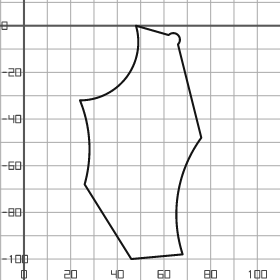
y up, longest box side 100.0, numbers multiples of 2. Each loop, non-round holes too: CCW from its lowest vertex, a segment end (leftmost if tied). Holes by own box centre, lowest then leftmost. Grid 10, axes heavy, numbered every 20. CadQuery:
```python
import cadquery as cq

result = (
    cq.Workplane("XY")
    .moveTo(46.0, -100.0)
    .lineTo(68.0, -98.0)
    .threePointArc((66.0, -72.0), (76.0, -48.0))
    .lineTo(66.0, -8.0)
    .threePointArc((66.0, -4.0), (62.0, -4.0))
    .lineTo(48.0, 0.0)
    .threePointArc((44.0, -22.0), (24.0, -32.0))
    .threePointArc((28.0, -50.0), (26.0, -68.0))
    .close()
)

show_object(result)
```